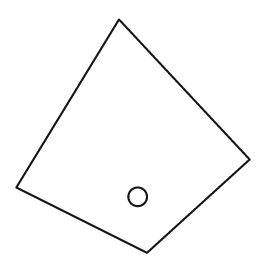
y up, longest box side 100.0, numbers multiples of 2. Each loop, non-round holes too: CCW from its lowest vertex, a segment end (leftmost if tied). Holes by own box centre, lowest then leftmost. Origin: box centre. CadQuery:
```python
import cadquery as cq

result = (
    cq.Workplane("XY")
    .moveTo(6.0, -50.0)
    .lineTo(50.0, -10.0)
    .lineTo(-6.0, 50.0)
    .lineTo(-50.0, -22.0)
    .close()
    .moveTo(2.0, -26.0)
    .circle(4.0)
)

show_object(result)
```